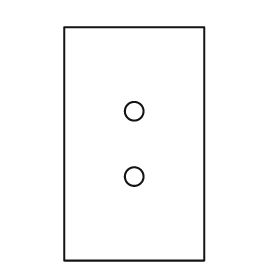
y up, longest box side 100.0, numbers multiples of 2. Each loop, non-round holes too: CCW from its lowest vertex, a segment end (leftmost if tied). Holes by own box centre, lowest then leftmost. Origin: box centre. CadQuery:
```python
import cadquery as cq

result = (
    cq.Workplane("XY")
    .moveTo(-30.0, -50.0)
    .lineTo(30.0, -50.0)
    .lineTo(30.0, 50.0)
    .lineTo(-30.0, 50.0)
    .close()
    .moveTo(0.0, -14.0)
    .circle(4.0)
    .moveTo(0.0, 14.0)
    .circle(4.0)
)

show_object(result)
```